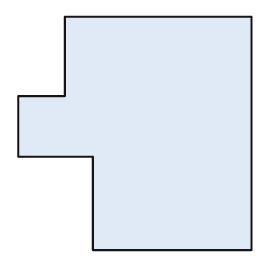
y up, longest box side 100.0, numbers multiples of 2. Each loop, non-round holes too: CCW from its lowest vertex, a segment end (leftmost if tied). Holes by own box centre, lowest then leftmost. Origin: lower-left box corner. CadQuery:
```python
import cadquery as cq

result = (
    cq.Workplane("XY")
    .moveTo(32.0, 0.0)
    .lineTo(100.0, 0.0)
    .lineTo(100.0, 100.0)
    .lineTo(20.0, 100.0)
    .lineTo(20.0, 66.0)
    .lineTo(0.0, 66.0)
    .lineTo(0.0, 40.0)
    .lineTo(32.0, 40.0)
    .close()
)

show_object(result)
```